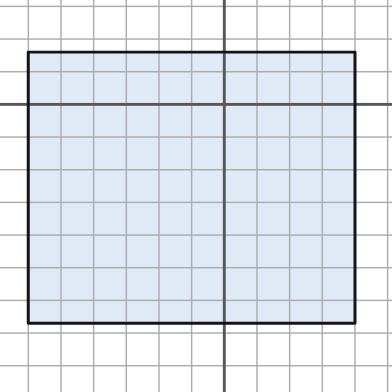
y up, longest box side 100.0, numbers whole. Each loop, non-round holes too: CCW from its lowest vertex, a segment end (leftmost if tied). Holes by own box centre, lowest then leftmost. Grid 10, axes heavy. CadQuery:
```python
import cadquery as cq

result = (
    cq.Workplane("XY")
    .moveTo(-60.0, -67.0)
    .lineTo(40.0, -67.0)
    .lineTo(40.0, 16.0)
    .lineTo(-60.0, 16.0)
    .close()
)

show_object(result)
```